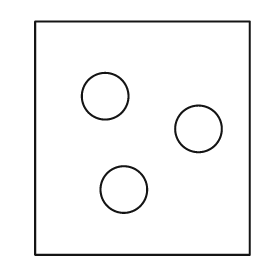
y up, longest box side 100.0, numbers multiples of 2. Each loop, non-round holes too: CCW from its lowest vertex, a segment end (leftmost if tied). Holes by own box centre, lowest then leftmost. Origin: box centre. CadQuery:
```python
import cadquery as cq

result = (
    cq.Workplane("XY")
    .moveTo(-46.0, -50.0)
    .lineTo(46.0, -50.0)
    .lineTo(46.0, 50.0)
    .lineTo(-46.0, 50.0)
    .close()
    .moveTo(-8.0, -22.0)
    .circle(10.0)
    .moveTo(24.0, 4.0)
    .circle(10.0)
    .moveTo(-16.0, 18.0)
    .circle(10.0)
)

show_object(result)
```